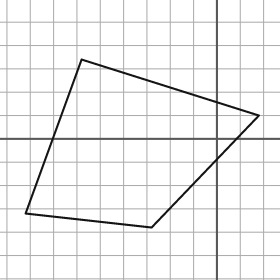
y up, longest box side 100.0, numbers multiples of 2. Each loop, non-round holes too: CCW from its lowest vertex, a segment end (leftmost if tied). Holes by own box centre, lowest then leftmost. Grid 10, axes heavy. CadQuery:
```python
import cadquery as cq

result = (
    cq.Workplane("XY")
    .moveTo(-28.0, -38.0)
    .lineTo(18.0, 10.0)
    .lineTo(-58.0, 34.0)
    .lineTo(-82.0, -32.0)
    .close()
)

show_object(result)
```